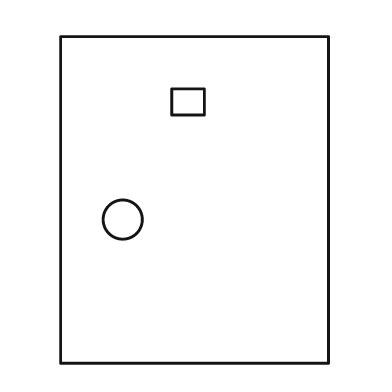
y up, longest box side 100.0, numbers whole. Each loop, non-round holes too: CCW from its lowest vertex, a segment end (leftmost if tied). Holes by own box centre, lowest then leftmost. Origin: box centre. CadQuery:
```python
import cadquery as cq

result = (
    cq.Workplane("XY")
    .moveTo(-41.0, -50.0)
    .lineTo(41.0, -50.0)
    .lineTo(41.0, 50.0)
    .lineTo(-41.0, 50.0)
    .close()
    .moveTo(-22.0, -6.0)
    .circle(6.0)
    .moveTo(-7.0, 26.0)
    .lineTo(3.0, 26.0)
    .lineTo(3.0, 34.0)
    .lineTo(-7.0, 34.0)
    .close()
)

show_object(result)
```